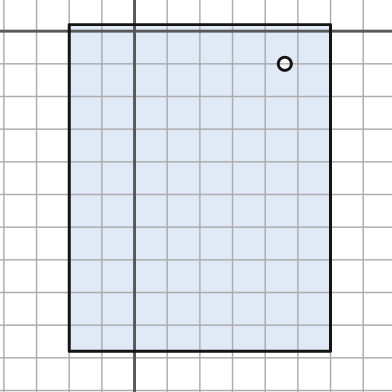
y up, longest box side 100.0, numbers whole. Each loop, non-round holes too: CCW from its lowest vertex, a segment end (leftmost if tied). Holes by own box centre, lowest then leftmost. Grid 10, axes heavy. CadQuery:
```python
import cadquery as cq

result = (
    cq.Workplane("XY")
    .moveTo(-20.0, -98.0)
    .lineTo(60.0, -98.0)
    .lineTo(60.0, 2.0)
    .lineTo(-20.0, 2.0)
    .close()
    .moveTo(46.0, -10.0)
    .circle(2.0)
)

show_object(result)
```